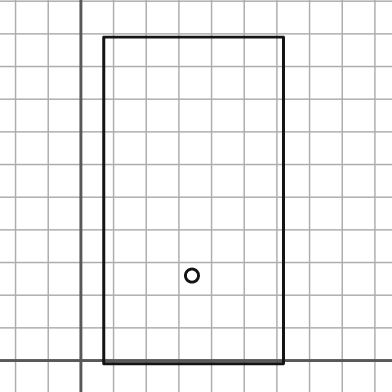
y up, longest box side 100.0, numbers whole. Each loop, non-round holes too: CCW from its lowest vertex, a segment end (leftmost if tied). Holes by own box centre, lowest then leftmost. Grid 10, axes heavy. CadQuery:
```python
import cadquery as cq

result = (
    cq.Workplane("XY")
    .moveTo(7.0, -1.0)
    .lineTo(62.0, -1.0)
    .lineTo(62.0, 99.0)
    .lineTo(7.0, 99.0)
    .close()
    .moveTo(34.0, 26.0)
    .circle(2.0)
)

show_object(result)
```